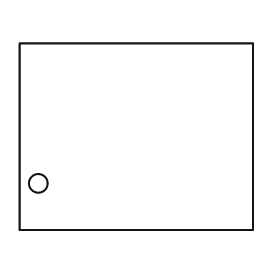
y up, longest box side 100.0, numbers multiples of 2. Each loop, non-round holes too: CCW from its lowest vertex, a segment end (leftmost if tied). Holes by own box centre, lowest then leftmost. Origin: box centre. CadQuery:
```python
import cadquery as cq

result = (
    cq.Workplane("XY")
    .moveTo(-50.0, -40.0)
    .lineTo(50.0, -40.0)
    .lineTo(50.0, 40.0)
    .lineTo(-50.0, 40.0)
    .close()
    .moveTo(-42.0, -20.0)
    .circle(4.0)
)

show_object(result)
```